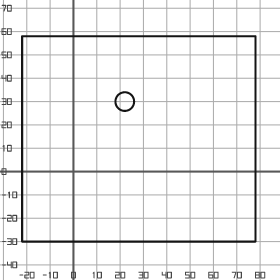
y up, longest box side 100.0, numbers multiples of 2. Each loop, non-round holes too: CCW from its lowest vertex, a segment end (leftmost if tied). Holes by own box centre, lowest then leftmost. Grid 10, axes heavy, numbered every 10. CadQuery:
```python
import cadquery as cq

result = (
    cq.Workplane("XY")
    .moveTo(-22.0, -30.0)
    .lineTo(78.0, -30.0)
    .lineTo(78.0, 58.0)
    .lineTo(-22.0, 58.0)
    .close()
    .moveTo(22.0, 30.0)
    .circle(4.0)
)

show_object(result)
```